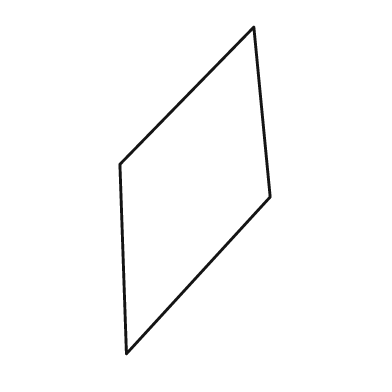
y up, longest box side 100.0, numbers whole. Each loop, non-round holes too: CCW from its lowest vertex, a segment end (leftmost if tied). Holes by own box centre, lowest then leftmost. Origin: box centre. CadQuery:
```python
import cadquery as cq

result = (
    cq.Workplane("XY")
    .moveTo(-21.0, -50.0)
    .lineTo(23.0, -2.0)
    .lineTo(18.0, 50.0)
    .lineTo(-23.0, 8.0)
    .close()
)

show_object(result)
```